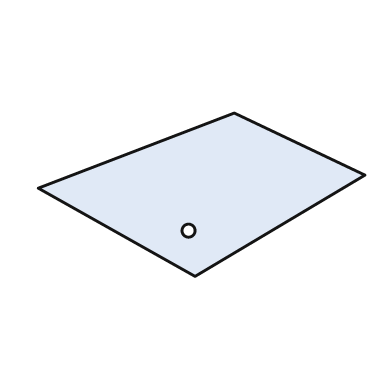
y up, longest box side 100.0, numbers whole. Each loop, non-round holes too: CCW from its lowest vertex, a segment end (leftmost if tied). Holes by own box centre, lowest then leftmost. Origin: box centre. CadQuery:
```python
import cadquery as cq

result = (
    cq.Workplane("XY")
    .moveTo(-2.0, -25.0)
    .lineTo(50.0, 6.0)
    .lineTo(10.0, 25.0)
    .lineTo(-50.0, 2.0)
    .close()
    .moveTo(-4.0, -11.0)
    .circle(2.0)
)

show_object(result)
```